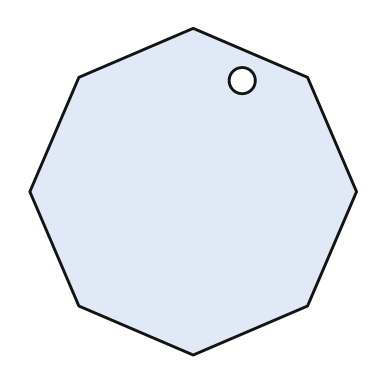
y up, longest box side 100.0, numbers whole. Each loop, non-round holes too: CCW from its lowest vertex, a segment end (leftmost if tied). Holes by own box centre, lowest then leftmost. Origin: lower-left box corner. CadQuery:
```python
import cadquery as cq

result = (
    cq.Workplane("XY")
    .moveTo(50.0, 0.0)
    .lineTo(85.0, 15.0)
    .lineTo(100.0, 50.0)
    .lineTo(85.0, 85.0)
    .lineTo(50.0, 100.0)
    .lineTo(15.0, 85.0)
    .lineTo(0.0, 50.0)
    .lineTo(15.0, 15.0)
    .close()
    .moveTo(65.0, 84.0)
    .circle(4.0)
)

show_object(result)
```